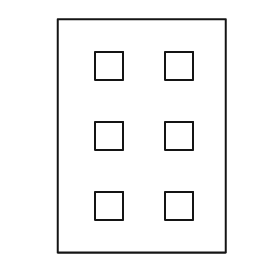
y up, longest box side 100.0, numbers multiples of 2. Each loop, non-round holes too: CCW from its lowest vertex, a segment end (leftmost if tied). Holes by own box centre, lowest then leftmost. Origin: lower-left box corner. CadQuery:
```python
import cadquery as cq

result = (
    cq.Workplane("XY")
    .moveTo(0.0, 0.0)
    .lineTo(72.0, 0.0)
    .lineTo(72.0, 100.0)
    .lineTo(0.0, 100.0)
    .close()
    .moveTo(16.0, 14.0)
    .lineTo(28.0, 14.0)
    .lineTo(28.0, 26.0)
    .lineTo(16.0, 26.0)
    .close()
    .moveTo(46.0, 14.0)
    .lineTo(58.0, 14.0)
    .lineTo(58.0, 26.0)
    .lineTo(46.0, 26.0)
    .close()
    .moveTo(16.0, 44.0)
    .lineTo(28.0, 44.0)
    .lineTo(28.0, 56.0)
    .lineTo(16.0, 56.0)
    .close()
    .moveTo(46.0, 44.0)
    .lineTo(58.0, 44.0)
    .lineTo(58.0, 56.0)
    .lineTo(46.0, 56.0)
    .close()
    .moveTo(16.0, 74.0)
    .lineTo(28.0, 74.0)
    .lineTo(28.0, 86.0)
    .lineTo(16.0, 86.0)
    .close()
    .moveTo(46.0, 74.0)
    .lineTo(58.0, 74.0)
    .lineTo(58.0, 86.0)
    .lineTo(46.0, 86.0)
    .close()
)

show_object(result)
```